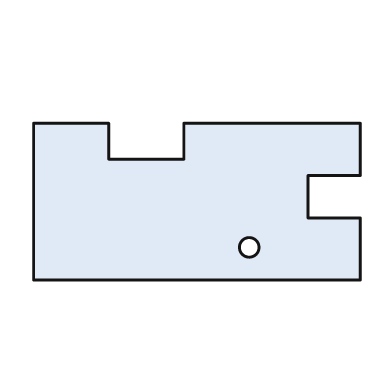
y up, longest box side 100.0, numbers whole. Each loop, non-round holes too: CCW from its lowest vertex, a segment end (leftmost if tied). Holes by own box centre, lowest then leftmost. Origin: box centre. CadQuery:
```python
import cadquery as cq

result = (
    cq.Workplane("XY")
    .moveTo(-50.0, -24.0)
    .lineTo(50.0, -24.0)
    .lineTo(50.0, -5.0)
    .lineTo(34.0, -5.0)
    .lineTo(34.0, 8.0)
    .lineTo(50.0, 8.0)
    .lineTo(50.0, 24.0)
    .lineTo(-4.0, 24.0)
    .lineTo(-4.0, 13.0)
    .lineTo(-27.0, 13.0)
    .lineTo(-27.0, 24.0)
    .lineTo(-50.0, 24.0)
    .close()
    .moveTo(16.0, -14.0)
    .circle(3.0)
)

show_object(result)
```